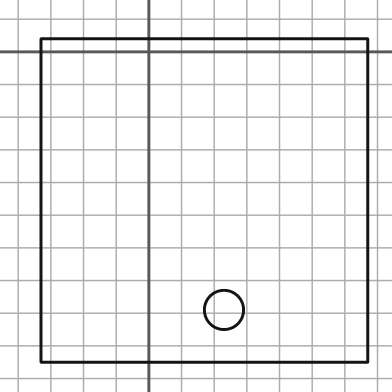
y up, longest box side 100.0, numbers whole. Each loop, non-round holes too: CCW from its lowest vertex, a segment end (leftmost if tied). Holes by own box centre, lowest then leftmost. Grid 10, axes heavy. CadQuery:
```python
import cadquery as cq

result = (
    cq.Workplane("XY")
    .moveTo(-33.0, -95.0)
    .lineTo(67.0, -95.0)
    .lineTo(67.0, 4.0)
    .lineTo(-33.0, 4.0)
    .close()
    .moveTo(23.0, -79.0)
    .circle(6.0)
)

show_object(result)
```